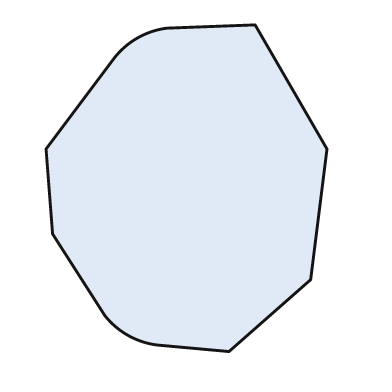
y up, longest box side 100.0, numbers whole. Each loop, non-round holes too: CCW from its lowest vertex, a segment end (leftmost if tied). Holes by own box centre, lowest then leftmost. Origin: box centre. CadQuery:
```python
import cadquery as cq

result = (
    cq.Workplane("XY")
    .moveTo(13.0, -50.0)
    .lineTo(38.0, -28.0)
    .lineTo(43.0, 12.0)
    .lineTo(21.0, 50.0)
    .lineTo(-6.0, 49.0)
    .threePointArc((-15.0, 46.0), (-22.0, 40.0))
    .lineTo(-43.0, 12.0)
    .lineTo(-41.0, -14.0)
    .lineTo(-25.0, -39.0)
    .threePointArc((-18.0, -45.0), (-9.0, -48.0))
    .close()
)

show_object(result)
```